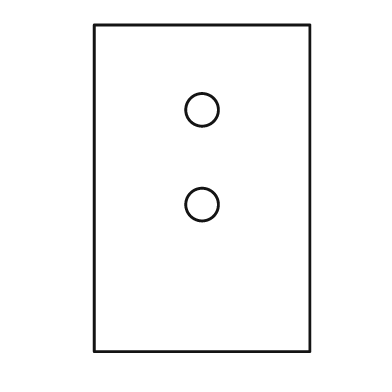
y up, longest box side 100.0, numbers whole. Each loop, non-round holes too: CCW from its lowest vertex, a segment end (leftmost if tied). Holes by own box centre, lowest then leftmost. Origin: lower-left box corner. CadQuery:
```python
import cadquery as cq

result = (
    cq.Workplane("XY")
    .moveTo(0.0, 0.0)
    .lineTo(66.0, 0.0)
    .lineTo(66.0, 100.0)
    .lineTo(0.0, 100.0)
    .close()
    .moveTo(33.0, 45.0)
    .circle(5.0)
    .moveTo(33.0, 74.0)
    .circle(5.0)
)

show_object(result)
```